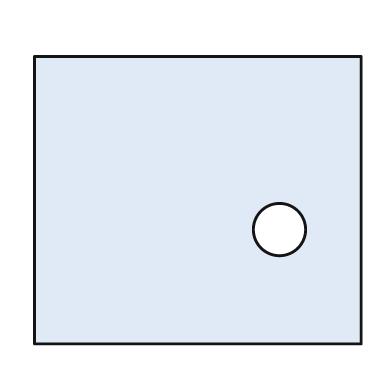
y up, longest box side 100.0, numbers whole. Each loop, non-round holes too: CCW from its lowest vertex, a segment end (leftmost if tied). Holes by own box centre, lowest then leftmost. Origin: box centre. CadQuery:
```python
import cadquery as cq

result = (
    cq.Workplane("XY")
    .moveTo(-50.0, -44.0)
    .lineTo(50.0, -44.0)
    .lineTo(50.0, 44.0)
    .lineTo(-50.0, 44.0)
    .close()
    .moveTo(25.0, -9.0)
    .circle(8.0)
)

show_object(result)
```